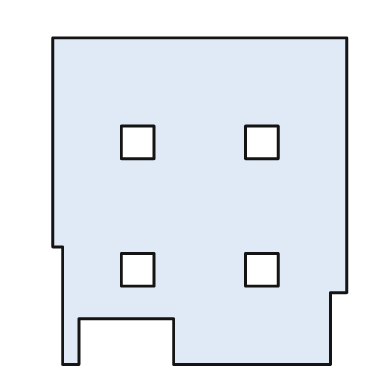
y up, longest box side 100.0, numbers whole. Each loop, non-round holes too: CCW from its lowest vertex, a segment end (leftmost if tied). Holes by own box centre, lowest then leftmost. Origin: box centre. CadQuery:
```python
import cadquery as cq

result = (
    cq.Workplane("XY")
    .moveTo(-42.0, -50.0)
    .lineTo(-37.0, -50.0)
    .lineTo(-37.0, -36.0)
    .lineTo(-8.0, -36.0)
    .lineTo(-8.0, -50.0)
    .lineTo(40.0, -50.0)
    .lineTo(40.0, -28.0)
    .lineTo(45.0, -28.0)
    .lineTo(45.0, 50.0)
    .lineTo(-45.0, 50.0)
    .lineTo(-45.0, -14.0)
    .lineTo(-42.0, -14.0)
    .close()
    .moveTo(-24.0, -26.0)
    .lineTo(-14.0, -26.0)
    .lineTo(-14.0, -16.0)
    .lineTo(-24.0, -16.0)
    .close()
    .moveTo(14.0, -26.0)
    .lineTo(24.0, -26.0)
    .lineTo(24.0, -16.0)
    .lineTo(14.0, -16.0)
    .close()
    .moveTo(-24.0, 13.0)
    .lineTo(-14.0, 13.0)
    .lineTo(-14.0, 23.0)
    .lineTo(-24.0, 23.0)
    .close()
    .moveTo(14.0, 13.0)
    .lineTo(24.0, 13.0)
    .lineTo(24.0, 23.0)
    .lineTo(14.0, 23.0)
    .close()
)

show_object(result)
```